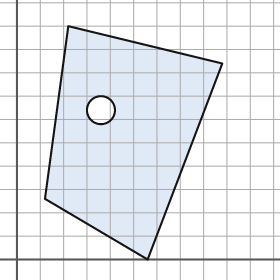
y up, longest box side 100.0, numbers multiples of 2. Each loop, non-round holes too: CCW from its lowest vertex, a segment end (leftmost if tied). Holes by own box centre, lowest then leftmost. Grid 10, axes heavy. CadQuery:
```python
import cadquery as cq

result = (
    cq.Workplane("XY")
    .moveTo(56.0, 0.0)
    .lineTo(88.0, 84.0)
    .lineTo(22.0, 100.0)
    .lineTo(12.0, 26.0)
    .close()
    .moveTo(36.0, 64.0)
    .circle(6.0)
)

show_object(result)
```